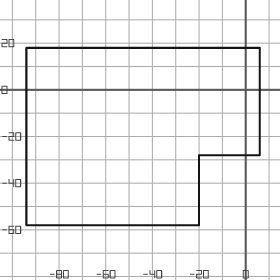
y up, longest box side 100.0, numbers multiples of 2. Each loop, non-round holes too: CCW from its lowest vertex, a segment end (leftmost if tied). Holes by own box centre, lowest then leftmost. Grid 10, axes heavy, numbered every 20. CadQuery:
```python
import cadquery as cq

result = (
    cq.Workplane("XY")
    .moveTo(-94.0, -58.0)
    .lineTo(-20.0, -58.0)
    .lineTo(-20.0, -28.0)
    .lineTo(6.0, -28.0)
    .lineTo(6.0, 18.0)
    .lineTo(-94.0, 18.0)
    .close()
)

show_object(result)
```